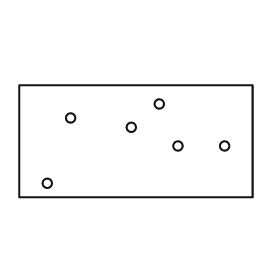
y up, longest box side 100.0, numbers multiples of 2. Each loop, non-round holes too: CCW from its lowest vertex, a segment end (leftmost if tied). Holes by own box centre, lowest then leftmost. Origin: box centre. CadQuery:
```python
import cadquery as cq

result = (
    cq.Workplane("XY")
    .moveTo(-50.0, -24.0)
    .lineTo(50.0, -24.0)
    .lineTo(50.0, 24.0)
    .lineTo(-50.0, 24.0)
    .close()
    .moveTo(-38.0, -18.0)
    .circle(2.0)
    .moveTo(18.0, -2.0)
    .circle(2.0)
    .moveTo(38.0, -2.0)
    .circle(2.0)
    .moveTo(-2.0, 6.0)
    .circle(2.0)
    .moveTo(-28.0, 10.0)
    .circle(2.0)
    .moveTo(10.0, 16.0)
    .circle(2.0)
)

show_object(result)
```